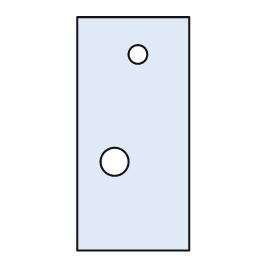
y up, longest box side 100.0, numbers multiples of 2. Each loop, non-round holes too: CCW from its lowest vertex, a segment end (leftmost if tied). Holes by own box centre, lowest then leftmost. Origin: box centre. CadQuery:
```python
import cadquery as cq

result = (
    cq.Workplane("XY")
    .moveTo(-24.0, -50.0)
    .lineTo(24.0, -50.0)
    .lineTo(24.0, 50.0)
    .lineTo(-24.0, 50.0)
    .close()
    .moveTo(-8.0, -12.0)
    .circle(6.0)
    .moveTo(2.0, 34.0)
    .circle(4.0)
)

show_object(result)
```